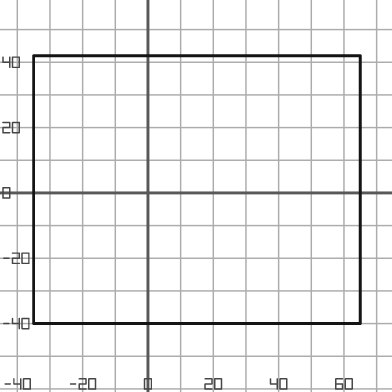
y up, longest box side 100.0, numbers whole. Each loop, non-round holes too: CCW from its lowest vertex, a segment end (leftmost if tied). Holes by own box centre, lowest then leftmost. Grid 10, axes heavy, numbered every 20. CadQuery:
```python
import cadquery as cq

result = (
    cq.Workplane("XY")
    .moveTo(-35.0, -40.0)
    .lineTo(65.0, -40.0)
    .lineTo(65.0, 42.0)
    .lineTo(-35.0, 42.0)
    .close()
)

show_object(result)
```